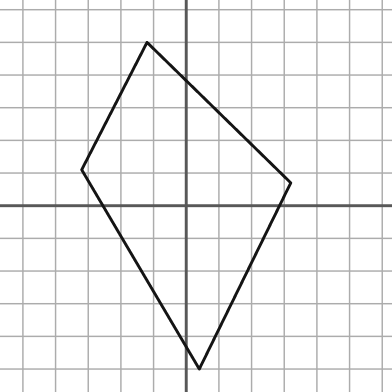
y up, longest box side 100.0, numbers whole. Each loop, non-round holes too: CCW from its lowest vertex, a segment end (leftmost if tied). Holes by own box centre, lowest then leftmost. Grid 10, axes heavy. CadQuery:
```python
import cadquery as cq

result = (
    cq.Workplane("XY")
    .moveTo(4.0, -50.0)
    .lineTo(32.0, 7.0)
    .lineTo(-12.0, 50.0)
    .lineTo(-32.0, 11.0)
    .close()
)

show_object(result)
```